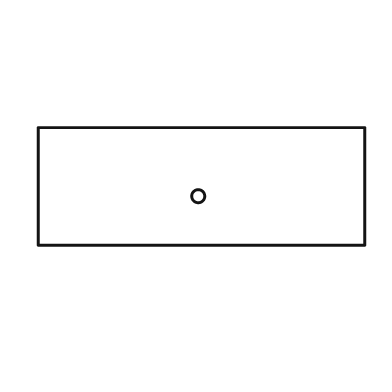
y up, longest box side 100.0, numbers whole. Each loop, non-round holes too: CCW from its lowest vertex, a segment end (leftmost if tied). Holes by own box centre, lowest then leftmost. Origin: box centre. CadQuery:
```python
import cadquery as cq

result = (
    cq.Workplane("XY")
    .moveTo(-50.0, -18.0)
    .lineTo(50.0, -18.0)
    .lineTo(50.0, 18.0)
    .lineTo(-50.0, 18.0)
    .close()
    .moveTo(-1.0, -3.0)
    .circle(2.0)
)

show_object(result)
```